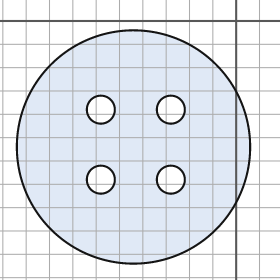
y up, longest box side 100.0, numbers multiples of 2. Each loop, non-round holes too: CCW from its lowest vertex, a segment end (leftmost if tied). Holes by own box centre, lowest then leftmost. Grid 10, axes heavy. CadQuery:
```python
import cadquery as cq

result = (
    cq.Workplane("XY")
    .moveTo(-44.0, -54.0)
    .circle(50.0)
    .moveTo(-58.0, -68.0)
    .circle(6.0)
    .moveTo(-28.0, -68.0)
    .circle(6.0)
    .moveTo(-58.0, -38.0)
    .circle(6.0)
    .moveTo(-28.0, -38.0)
    .circle(6.0)
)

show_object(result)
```